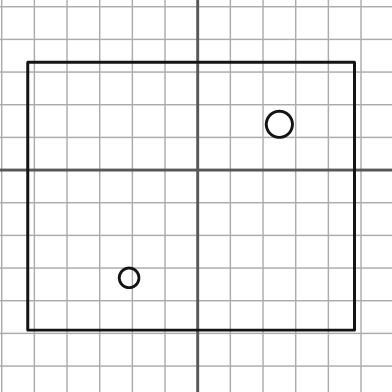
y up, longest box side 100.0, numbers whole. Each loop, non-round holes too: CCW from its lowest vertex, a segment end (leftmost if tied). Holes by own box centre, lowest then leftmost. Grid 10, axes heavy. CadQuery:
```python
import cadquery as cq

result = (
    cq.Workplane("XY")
    .moveTo(-52.0, -49.0)
    .lineTo(48.0, -49.0)
    .lineTo(48.0, 33.0)
    .lineTo(-52.0, 33.0)
    .close()
    .moveTo(-21.0, -33.0)
    .circle(3.0)
    .moveTo(25.0, 14.0)
    .circle(4.0)
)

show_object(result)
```